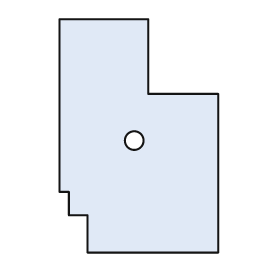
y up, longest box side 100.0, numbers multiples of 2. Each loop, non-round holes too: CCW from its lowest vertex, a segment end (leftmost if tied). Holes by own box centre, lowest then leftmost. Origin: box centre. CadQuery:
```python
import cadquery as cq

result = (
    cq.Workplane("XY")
    .moveTo(-22.0, -50.0)
    .lineTo(34.0, -50.0)
    .lineTo(34.0, 18.0)
    .lineTo(4.0, 18.0)
    .lineTo(4.0, 50.0)
    .lineTo(-34.0, 50.0)
    .lineTo(-34.0, -24.0)
    .lineTo(-30.0, -24.0)
    .lineTo(-30.0, -34.0)
    .lineTo(-22.0, -34.0)
    .close()
    .moveTo(-2.0, -2.0)
    .circle(4.0)
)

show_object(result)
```